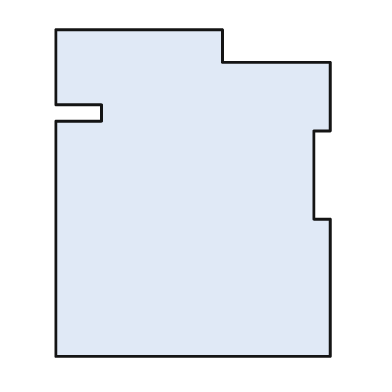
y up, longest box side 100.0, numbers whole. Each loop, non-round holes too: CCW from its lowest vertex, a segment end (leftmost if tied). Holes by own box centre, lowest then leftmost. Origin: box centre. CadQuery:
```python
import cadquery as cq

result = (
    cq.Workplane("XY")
    .moveTo(-42.0, -50.0)
    .lineTo(42.0, -50.0)
    .lineTo(42.0, -8.0)
    .lineTo(37.0, -8.0)
    .lineTo(37.0, 19.0)
    .lineTo(42.0, 19.0)
    .lineTo(42.0, 40.0)
    .lineTo(9.0, 40.0)
    .lineTo(9.0, 50.0)
    .lineTo(-42.0, 50.0)
    .lineTo(-42.0, 27.0)
    .lineTo(-28.0, 27.0)
    .lineTo(-28.0, 22.0)
    .lineTo(-42.0, 22.0)
    .close()
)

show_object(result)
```